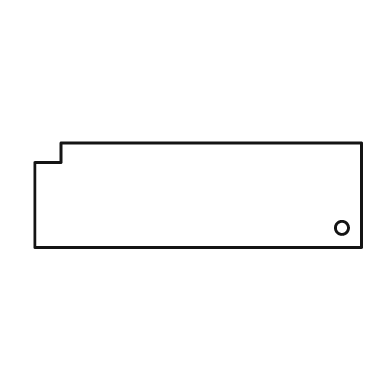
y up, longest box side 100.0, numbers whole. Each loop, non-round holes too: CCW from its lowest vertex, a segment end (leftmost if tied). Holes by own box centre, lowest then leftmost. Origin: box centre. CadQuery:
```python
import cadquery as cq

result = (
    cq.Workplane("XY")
    .moveTo(-50.0, -16.0)
    .lineTo(50.0, -16.0)
    .lineTo(50.0, 16.0)
    .lineTo(-42.0, 16.0)
    .lineTo(-42.0, 10.0)
    .lineTo(-50.0, 10.0)
    .close()
    .moveTo(44.0, -10.0)
    .circle(2.0)
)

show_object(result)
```